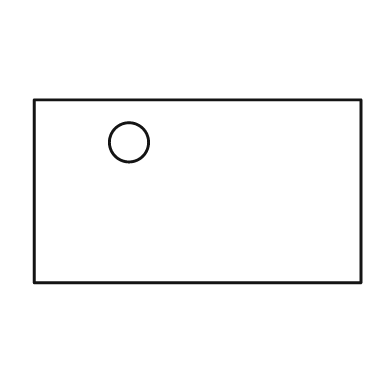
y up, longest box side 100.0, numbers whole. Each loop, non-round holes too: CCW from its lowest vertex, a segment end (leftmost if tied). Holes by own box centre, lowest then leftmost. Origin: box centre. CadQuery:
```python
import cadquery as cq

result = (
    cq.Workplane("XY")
    .moveTo(-50.0, -28.0)
    .lineTo(50.0, -28.0)
    .lineTo(50.0, 28.0)
    .lineTo(-50.0, 28.0)
    .close()
    .moveTo(-21.0, 15.0)
    .circle(6.0)
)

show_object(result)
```